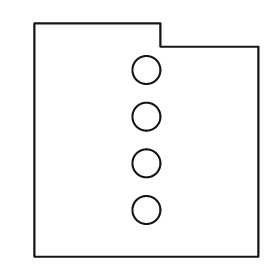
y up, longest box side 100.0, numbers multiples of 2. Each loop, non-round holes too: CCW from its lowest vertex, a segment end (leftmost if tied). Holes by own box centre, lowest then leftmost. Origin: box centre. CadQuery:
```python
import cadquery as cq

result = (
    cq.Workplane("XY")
    .moveTo(-48.0, -50.0)
    .lineTo(48.0, -50.0)
    .lineTo(48.0, 40.0)
    .lineTo(6.0, 40.0)
    .lineTo(6.0, 50.0)
    .lineTo(-48.0, 50.0)
    .close()
    .moveTo(0.0, -30.0)
    .circle(6.0)
    .moveTo(0.0, -10.0)
    .circle(6.0)
    .moveTo(0.0, 10.0)
    .circle(6.0)
    .moveTo(0.0, 30.0)
    .circle(6.0)
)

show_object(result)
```